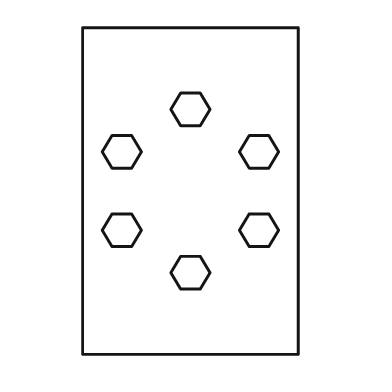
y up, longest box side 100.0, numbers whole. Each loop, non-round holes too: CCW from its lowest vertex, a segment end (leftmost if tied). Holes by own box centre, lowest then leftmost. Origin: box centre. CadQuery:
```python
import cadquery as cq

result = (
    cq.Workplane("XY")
    .moveTo(-33.0, -50.0)
    .lineTo(33.0, -50.0)
    .lineTo(33.0, 50.0)
    .lineTo(-33.0, 50.0)
    .close()
    .moveTo(-3.0, -30.0)
    .lineTo(3.0, -30.0)
    .lineTo(6.0, -25.0)
    .lineTo(3.0, -20.0)
    .lineTo(-3.0, -20.0)
    .lineTo(-6.0, -25.0)
    .close()
    .moveTo(-24.0, -17.0)
    .lineTo(-18.0, -17.0)
    .lineTo(-15.0, -12.0)
    .lineTo(-18.0, -7.0)
    .lineTo(-24.0, -7.0)
    .lineTo(-27.0, -12.0)
    .close()
    .moveTo(18.0, -17.0)
    .lineTo(24.0, -17.0)
    .lineTo(27.0, -12.0)
    .lineTo(24.0, -7.0)
    .lineTo(18.0, -7.0)
    .lineTo(15.0, -12.0)
    .close()
    .moveTo(-24.0, 7.0)
    .lineTo(-18.0, 7.0)
    .lineTo(-15.0, 12.0)
    .lineTo(-18.0, 17.0)
    .lineTo(-24.0, 17.0)
    .lineTo(-27.0, 12.0)
    .close()
    .moveTo(18.0, 7.0)
    .lineTo(24.0, 7.0)
    .lineTo(27.0, 12.0)
    .lineTo(24.0, 17.0)
    .lineTo(18.0, 17.0)
    .lineTo(15.0, 12.0)
    .close()
    .moveTo(-3.0, 20.0)
    .lineTo(3.0, 20.0)
    .lineTo(6.0, 25.0)
    .lineTo(3.0, 30.0)
    .lineTo(-3.0, 30.0)
    .lineTo(-6.0, 25.0)
    .close()
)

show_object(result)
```